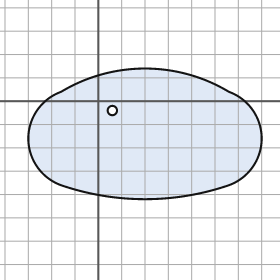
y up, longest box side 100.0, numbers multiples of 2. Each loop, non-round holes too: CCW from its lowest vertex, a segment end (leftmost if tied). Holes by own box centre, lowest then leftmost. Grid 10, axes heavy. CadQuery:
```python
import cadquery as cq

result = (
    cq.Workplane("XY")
    .moveTo(-16.0, -36.0)
    .threePointArc((20.0, -42.0), (56.0, -36.0))
    .threePointArc((70.0, -16.0), (56.0, 4.0))
    .threePointArc((20.0, 14.0), (-16.0, 4.0))
    .threePointArc((-30.0, -16.0), (-16.0, -36.0))
    .close()
    .moveTo(6.0, -4.0)
    .circle(2.0)
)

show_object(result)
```